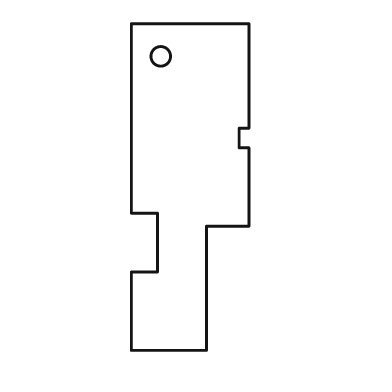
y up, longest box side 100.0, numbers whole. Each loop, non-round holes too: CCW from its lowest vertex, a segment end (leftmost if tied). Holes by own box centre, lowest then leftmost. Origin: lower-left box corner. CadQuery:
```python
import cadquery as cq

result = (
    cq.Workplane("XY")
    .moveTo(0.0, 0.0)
    .lineTo(23.0, 0.0)
    .lineTo(23.0, 38.0)
    .lineTo(36.0, 38.0)
    .lineTo(36.0, 62.0)
    .lineTo(33.0, 62.0)
    .lineTo(33.0, 68.0)
    .lineTo(36.0, 68.0)
    .lineTo(36.0, 100.0)
    .lineTo(0.0, 100.0)
    .lineTo(0.0, 42.0)
    .lineTo(8.0, 42.0)
    .lineTo(8.0, 24.0)
    .lineTo(0.0, 24.0)
    .close()
    .moveTo(9.0, 90.0)
    .circle(3.0)
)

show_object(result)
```